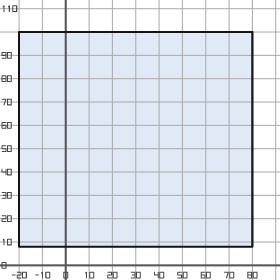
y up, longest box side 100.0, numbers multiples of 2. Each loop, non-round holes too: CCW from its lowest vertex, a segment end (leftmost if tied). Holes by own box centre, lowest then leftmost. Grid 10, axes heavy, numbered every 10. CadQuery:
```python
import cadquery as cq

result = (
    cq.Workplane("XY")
    .moveTo(-20.0, 8.0)
    .lineTo(80.0, 8.0)
    .lineTo(80.0, 100.0)
    .lineTo(-20.0, 100.0)
    .close()
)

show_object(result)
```